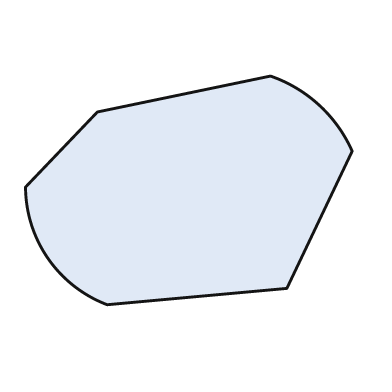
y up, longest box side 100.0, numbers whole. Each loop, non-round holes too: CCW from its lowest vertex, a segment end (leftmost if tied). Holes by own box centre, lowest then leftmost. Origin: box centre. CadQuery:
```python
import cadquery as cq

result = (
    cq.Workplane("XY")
    .moveTo(-25.0, -35.0)
    .lineTo(30.0, -30.0)
    .lineTo(50.0, 12.0)
    .threePointArc((40.0, 26.0), (25.0, 35.0))
    .lineTo(-28.0, 24.0)
    .lineTo(-50.0, 1.0)
    .threePointArc((-43.0, -21.0), (-25.0, -35.0))
    .close()
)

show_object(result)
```